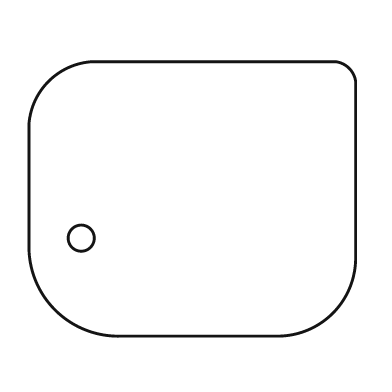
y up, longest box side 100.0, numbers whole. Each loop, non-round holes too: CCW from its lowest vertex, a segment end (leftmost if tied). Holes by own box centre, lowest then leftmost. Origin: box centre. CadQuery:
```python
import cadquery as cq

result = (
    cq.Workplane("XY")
    .moveTo(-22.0, -42.0)
    .lineTo(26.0, -42.0)
    .threePointArc((43.0, -35.0), (50.0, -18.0))
    .lineTo(50.0, 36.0)
    .threePointArc((48.0, 40.0), (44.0, 42.0))
    .lineTo(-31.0, 42.0)
    .threePointArc((-44.0, 36.0), (-50.0, 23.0))
    .lineTo(-50.0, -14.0)
    .threePointArc((-42.0, -34.0), (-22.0, -42.0))
    .close()
    .moveTo(-34.0, -12.0)
    .circle(4.0)
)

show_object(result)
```